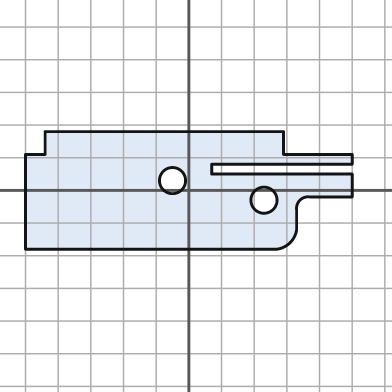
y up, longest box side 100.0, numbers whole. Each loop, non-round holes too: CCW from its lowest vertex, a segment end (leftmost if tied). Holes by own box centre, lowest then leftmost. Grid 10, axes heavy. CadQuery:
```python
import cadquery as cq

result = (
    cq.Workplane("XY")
    .moveTo(-50.0, -18.0)
    .lineTo(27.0, -18.0)
    .threePointArc((31.0, -16.0), (33.0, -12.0))
    .lineTo(33.0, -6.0)
    .threePointArc((34.0, -3.0), (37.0, -2.0))
    .lineTo(50.0, -2.0)
    .lineTo(50.0, 5.0)
    .lineTo(7.0, 5.0)
    .lineTo(7.0, 8.0)
    .lineTo(50.0, 8.0)
    .lineTo(50.0, 11.0)
    .lineTo(29.0, 11.0)
    .lineTo(29.0, 18.0)
    .lineTo(-44.0, 18.0)
    .lineTo(-44.0, 11.0)
    .lineTo(-50.0, 11.0)
    .close()
    .moveTo(23.0, -3.0)
    .circle(4.0)
    .moveTo(-5.0, 3.0)
    .circle(4.0)
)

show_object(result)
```